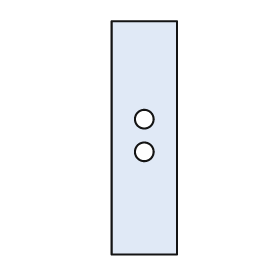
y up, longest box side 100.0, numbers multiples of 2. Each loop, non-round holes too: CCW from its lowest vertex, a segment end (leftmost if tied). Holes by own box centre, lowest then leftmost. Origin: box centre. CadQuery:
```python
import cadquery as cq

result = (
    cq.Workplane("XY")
    .moveTo(-14.0, -50.0)
    .lineTo(14.0, -50.0)
    .lineTo(14.0, 50.0)
    .lineTo(-14.0, 50.0)
    .close()
    .moveTo(0.0, -6.0)
    .circle(4.0)
    .moveTo(0.0, 8.0)
    .circle(4.0)
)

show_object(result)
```